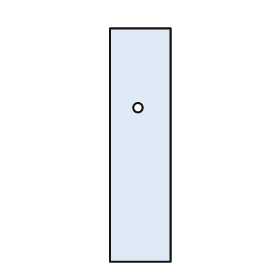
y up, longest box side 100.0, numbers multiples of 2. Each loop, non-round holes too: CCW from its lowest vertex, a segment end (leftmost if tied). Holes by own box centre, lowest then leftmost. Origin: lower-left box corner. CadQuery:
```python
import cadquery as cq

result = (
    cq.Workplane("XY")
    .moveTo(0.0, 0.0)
    .lineTo(26.0, 0.0)
    .lineTo(26.0, 100.0)
    .lineTo(0.0, 100.0)
    .close()
    .moveTo(12.0, 66.0)
    .circle(2.0)
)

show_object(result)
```